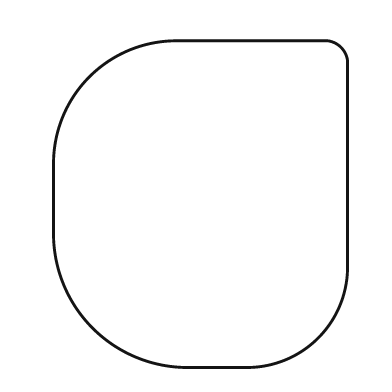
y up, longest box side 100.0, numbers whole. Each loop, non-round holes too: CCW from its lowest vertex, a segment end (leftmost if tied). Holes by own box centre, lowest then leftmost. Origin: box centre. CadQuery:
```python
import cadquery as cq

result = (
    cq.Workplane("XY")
    .moveTo(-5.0, -50.0)
    .lineTo(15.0, -50.0)
    .threePointArc((36.0, -41.0), (45.0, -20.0))
    .lineTo(45.0, 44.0)
    .threePointArc((43.0, 48.0), (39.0, 50.0))
    .lineTo(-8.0, 50.0)
    .threePointArc((-34.0, 39.0), (-45.0, 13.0))
    .lineTo(-45.0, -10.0)
    .threePointArc((-33.0, -38.0), (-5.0, -50.0))
    .close()
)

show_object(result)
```